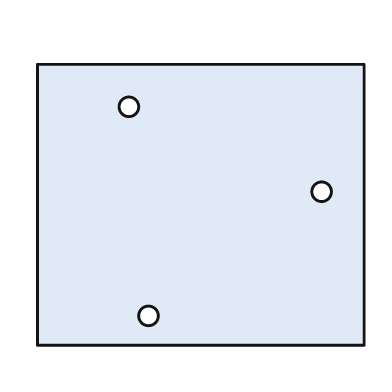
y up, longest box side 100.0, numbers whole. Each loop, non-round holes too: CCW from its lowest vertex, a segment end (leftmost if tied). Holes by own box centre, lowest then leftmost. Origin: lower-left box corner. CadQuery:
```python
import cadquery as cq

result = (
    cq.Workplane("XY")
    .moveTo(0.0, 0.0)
    .lineTo(100.0, 0.0)
    .lineTo(100.0, 86.0)
    .lineTo(0.0, 86.0)
    .close()
    .moveTo(34.0, 9.0)
    .circle(3.0)
    .moveTo(87.0, 47.0)
    .circle(3.0)
    .moveTo(28.0, 73.0)
    .circle(3.0)
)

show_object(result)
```